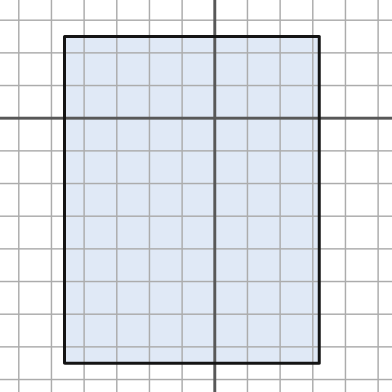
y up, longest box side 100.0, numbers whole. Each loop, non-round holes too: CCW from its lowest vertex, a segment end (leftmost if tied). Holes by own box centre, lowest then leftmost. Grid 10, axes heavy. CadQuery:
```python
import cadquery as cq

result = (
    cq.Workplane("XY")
    .moveTo(-46.0, -75.0)
    .lineTo(32.0, -75.0)
    .lineTo(32.0, 25.0)
    .lineTo(-46.0, 25.0)
    .close()
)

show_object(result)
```